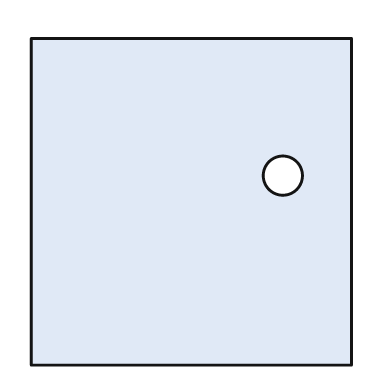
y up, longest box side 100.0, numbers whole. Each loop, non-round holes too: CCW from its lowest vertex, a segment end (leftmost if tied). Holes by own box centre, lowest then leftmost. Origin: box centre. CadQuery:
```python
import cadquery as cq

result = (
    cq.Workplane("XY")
    .moveTo(-49.0, -50.0)
    .lineTo(49.0, -50.0)
    .lineTo(49.0, 50.0)
    .lineTo(-49.0, 50.0)
    .close()
    .moveTo(28.0, 8.0)
    .circle(6.0)
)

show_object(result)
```